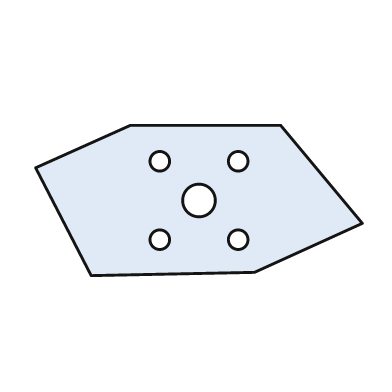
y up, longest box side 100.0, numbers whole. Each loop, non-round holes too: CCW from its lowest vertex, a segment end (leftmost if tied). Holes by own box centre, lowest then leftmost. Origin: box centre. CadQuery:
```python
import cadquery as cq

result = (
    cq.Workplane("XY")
    .moveTo(-33.0, -23.0)
    .lineTo(17.0, -22.0)
    .lineTo(50.0, -7.0)
    .lineTo(25.0, 23.0)
    .lineTo(-21.0, 23.0)
    .lineTo(-50.0, 10.0)
    .close()
    .moveTo(-12.0, -12.0)
    .circle(3.0)
    .moveTo(12.0, -12.0)
    .circle(3.0)
    .moveTo(0.0, 0.0)
    .circle(5.0)
    .moveTo(-12.0, 12.0)
    .circle(3.0)
    .moveTo(12.0, 12.0)
    .circle(3.0)
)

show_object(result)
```